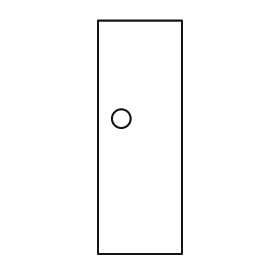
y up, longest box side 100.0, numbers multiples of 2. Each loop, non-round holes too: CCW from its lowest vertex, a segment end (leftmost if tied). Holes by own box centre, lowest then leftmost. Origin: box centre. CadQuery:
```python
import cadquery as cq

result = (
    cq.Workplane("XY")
    .moveTo(-18.0, -50.0)
    .lineTo(18.0, -50.0)
    .lineTo(18.0, 50.0)
    .lineTo(-18.0, 50.0)
    .close()
    .moveTo(-8.0, 8.0)
    .circle(4.0)
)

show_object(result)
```